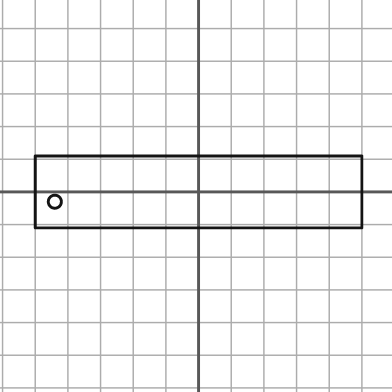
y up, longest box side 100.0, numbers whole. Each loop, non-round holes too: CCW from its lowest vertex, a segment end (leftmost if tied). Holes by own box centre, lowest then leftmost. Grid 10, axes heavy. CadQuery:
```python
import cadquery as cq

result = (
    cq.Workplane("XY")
    .moveTo(-50.0, -11.0)
    .lineTo(50.0, -11.0)
    .lineTo(50.0, 11.0)
    .lineTo(-50.0, 11.0)
    .close()
    .moveTo(-44.0, -3.0)
    .circle(2.0)
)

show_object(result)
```